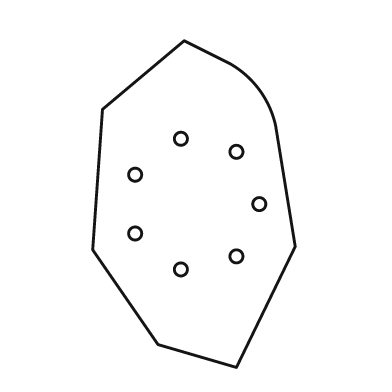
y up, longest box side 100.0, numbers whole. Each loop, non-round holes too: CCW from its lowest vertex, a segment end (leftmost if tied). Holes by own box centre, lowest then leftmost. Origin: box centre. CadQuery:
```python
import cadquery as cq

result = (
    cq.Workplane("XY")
    .moveTo(13.0, -50.0)
    .lineTo(31.0, -13.0)
    .lineTo(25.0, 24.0)
    .threePointArc((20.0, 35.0), (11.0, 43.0))
    .lineTo(-3.0, 50.0)
    .lineTo(-28.0, 29.0)
    .lineTo(-31.0, -14.0)
    .lineTo(-11.0, -43.0)
    .close()
    .moveTo(-4.0, -20.0)
    .circle(2.0)
    .moveTo(13.0, -16.0)
    .circle(2.0)
    .moveTo(-18.0, -9.0)
    .circle(2.0)
    .moveTo(20.0, 0.0)
    .circle(2.0)
    .moveTo(-18.0, 9.0)
    .circle(2.0)
    .moveTo(13.0, 16.0)
    .circle(2.0)
    .moveTo(-4.0, 20.0)
    .circle(2.0)
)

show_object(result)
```